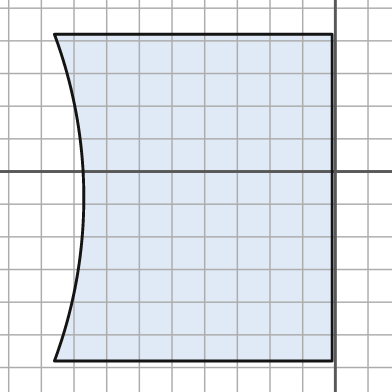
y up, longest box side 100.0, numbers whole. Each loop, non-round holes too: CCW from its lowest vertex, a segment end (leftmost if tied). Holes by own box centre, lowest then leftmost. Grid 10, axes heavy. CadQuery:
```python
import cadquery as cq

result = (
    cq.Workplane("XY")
    .moveTo(-86.0, -58.0)
    .lineTo(-1.0, -58.0)
    .lineTo(-1.0, 42.0)
    .lineTo(-86.0, 42.0)
    .threePointArc((-77.0, -8.0), (-86.0, -58.0))
    .close()
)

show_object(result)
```